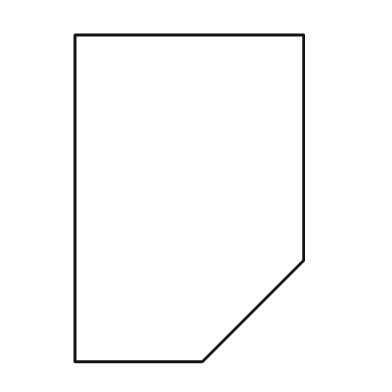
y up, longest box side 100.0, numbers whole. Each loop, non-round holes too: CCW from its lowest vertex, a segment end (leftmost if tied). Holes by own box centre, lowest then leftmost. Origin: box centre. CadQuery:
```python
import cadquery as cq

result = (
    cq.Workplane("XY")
    .moveTo(-35.0, -50.0)
    .lineTo(4.0, -50.0)
    .lineTo(35.0, -19.0)
    .lineTo(35.0, 50.0)
    .lineTo(-35.0, 50.0)
    .close()
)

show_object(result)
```